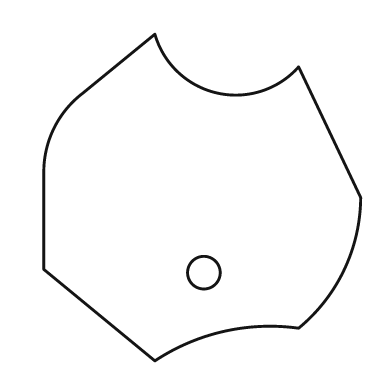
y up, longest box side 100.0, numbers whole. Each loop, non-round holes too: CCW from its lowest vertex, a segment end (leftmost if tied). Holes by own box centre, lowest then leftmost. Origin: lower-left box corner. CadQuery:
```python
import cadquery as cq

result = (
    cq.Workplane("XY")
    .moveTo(34.0, 0.0)
    .threePointArc((55.0, 9.0), (78.0, 10.0))
    .threePointArc((92.0, 28.0), (97.0, 50.0))
    .lineTo(78.0, 90.0)
    .threePointArc((53.0, 82.0), (34.0, 100.0))
    .lineTo(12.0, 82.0)
    .threePointArc((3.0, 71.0), (0.0, 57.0))
    .lineTo(0.0, 28.0)
    .close()
    .moveTo(49.0, 27.0)
    .circle(5.0)
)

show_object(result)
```